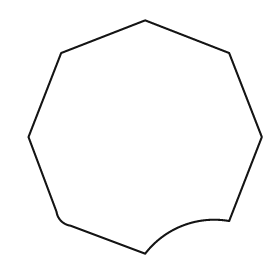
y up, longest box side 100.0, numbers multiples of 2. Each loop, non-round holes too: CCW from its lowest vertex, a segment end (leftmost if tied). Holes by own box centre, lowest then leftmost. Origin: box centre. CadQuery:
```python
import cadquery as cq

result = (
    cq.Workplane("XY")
    .moveTo(0.0, -50.0)
    .threePointArc((16.0, -38.0), (36.0, -36.0))
    .lineTo(50.0, 0.0)
    .lineTo(36.0, 36.0)
    .lineTo(0.0, 50.0)
    .lineTo(-36.0, 36.0)
    .lineTo(-50.0, 0.0)
    .lineTo(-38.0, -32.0)
    .threePointArc((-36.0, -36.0), (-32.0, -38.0))
    .close()
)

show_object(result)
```